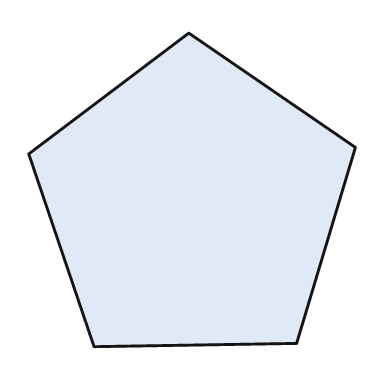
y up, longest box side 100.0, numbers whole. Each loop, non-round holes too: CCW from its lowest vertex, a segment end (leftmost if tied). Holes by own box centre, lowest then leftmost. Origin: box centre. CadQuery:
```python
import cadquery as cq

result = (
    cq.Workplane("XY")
    .moveTo(-30.0, -48.0)
    .lineTo(32.0, -47.0)
    .lineTo(50.0, 13.0)
    .lineTo(-1.0, 48.0)
    .lineTo(-50.0, 11.0)
    .close()
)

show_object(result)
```